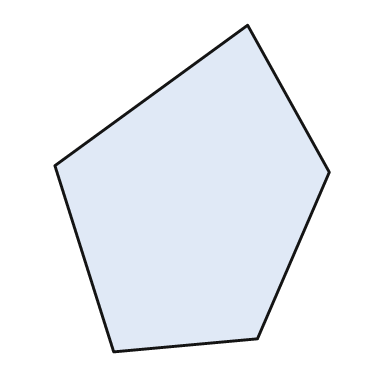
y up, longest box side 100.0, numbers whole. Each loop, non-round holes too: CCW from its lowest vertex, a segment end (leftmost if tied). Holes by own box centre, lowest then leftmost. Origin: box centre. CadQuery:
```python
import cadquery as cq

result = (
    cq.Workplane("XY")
    .moveTo(-24.0, -50.0)
    .lineTo(20.0, -46.0)
    .lineTo(42.0, 5.0)
    .lineTo(17.0, 50.0)
    .lineTo(-42.0, 7.0)
    .close()
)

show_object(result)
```